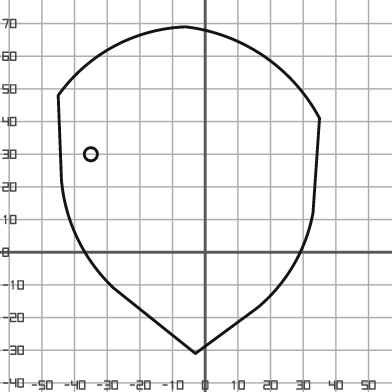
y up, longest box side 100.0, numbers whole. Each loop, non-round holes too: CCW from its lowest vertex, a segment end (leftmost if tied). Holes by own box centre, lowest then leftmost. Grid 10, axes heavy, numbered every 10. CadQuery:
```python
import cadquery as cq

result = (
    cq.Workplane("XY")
    .moveTo(-3.0, -31.0)
    .lineTo(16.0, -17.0)
    .threePointArc((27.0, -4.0), (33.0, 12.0))
    .lineTo(35.0, 41.0)
    .threePointArc((18.0, 60.0), (-6.0, 69.0))
    .threePointArc((-28.0, 63.0), (-45.0, 48.0))
    .lineTo(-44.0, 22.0)
    .threePointArc((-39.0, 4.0), (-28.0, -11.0))
    .close()
    .moveTo(-35.0, 30.0)
    .circle(2.0)
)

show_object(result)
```